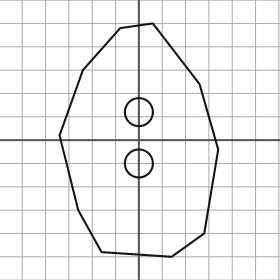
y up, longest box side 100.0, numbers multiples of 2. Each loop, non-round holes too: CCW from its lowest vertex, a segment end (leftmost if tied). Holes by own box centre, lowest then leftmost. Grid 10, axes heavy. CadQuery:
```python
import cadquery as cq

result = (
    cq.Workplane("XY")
    .moveTo(14.0, -50.0)
    .lineTo(28.0, -40.0)
    .lineTo(34.0, -4.0)
    .lineTo(26.0, 24.0)
    .lineTo(6.0, 50.0)
    .lineTo(-8.0, 48.0)
    .lineTo(-24.0, 30.0)
    .lineTo(-34.0, 2.0)
    .lineTo(-26.0, -30.0)
    .lineTo(-16.0, -48.0)
    .close()
    .moveTo(0.0, -10.0)
    .circle(6.0)
    .moveTo(0.0, 12.0)
    .circle(6.0)
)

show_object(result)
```